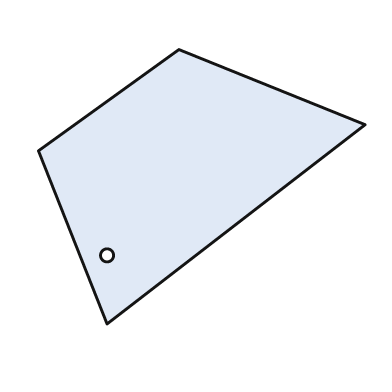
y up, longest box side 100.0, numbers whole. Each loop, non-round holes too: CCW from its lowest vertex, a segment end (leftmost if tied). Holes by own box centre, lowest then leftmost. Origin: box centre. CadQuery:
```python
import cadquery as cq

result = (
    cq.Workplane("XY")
    .moveTo(-29.0, -42.0)
    .lineTo(50.0, 19.0)
    .lineTo(-7.0, 42.0)
    .lineTo(-50.0, 11.0)
    .close()
    .moveTo(-29.0, -21.0)
    .circle(2.0)
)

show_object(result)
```